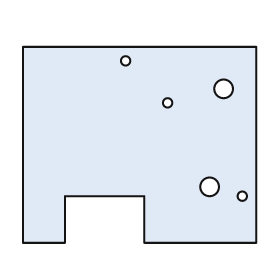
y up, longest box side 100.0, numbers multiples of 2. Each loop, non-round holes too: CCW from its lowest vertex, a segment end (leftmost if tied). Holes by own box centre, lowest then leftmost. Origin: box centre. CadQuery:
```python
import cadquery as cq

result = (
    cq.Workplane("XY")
    .moveTo(-50.0, -42.0)
    .lineTo(-32.0, -42.0)
    .lineTo(-32.0, -22.0)
    .lineTo(2.0, -22.0)
    .lineTo(2.0, -42.0)
    .lineTo(50.0, -42.0)
    .lineTo(50.0, 42.0)
    .lineTo(-50.0, 42.0)
    .close()
    .moveTo(44.0, -22.0)
    .circle(2.0)
    .moveTo(30.0, -18.0)
    .circle(4.0)
    .moveTo(12.0, 18.0)
    .circle(2.0)
    .moveTo(36.0, 24.0)
    .circle(4.0)
    .moveTo(-6.0, 36.0)
    .circle(2.0)
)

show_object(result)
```